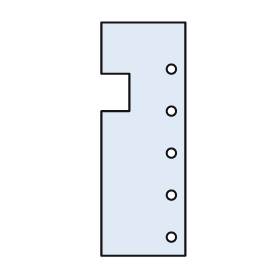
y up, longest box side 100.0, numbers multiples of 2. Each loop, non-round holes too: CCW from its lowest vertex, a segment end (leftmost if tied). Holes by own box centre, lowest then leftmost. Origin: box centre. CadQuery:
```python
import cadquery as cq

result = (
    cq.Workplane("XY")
    .moveTo(-18.0, -50.0)
    .lineTo(18.0, -50.0)
    .lineTo(18.0, 50.0)
    .lineTo(-18.0, 50.0)
    .lineTo(-18.0, 28.0)
    .lineTo(-6.0, 28.0)
    .lineTo(-6.0, 12.0)
    .lineTo(-18.0, 12.0)
    .close()
    .moveTo(12.0, -42.0)
    .circle(2.0)
    .moveTo(12.0, -24.0)
    .circle(2.0)
    .moveTo(12.0, -6.0)
    .circle(2.0)
    .moveTo(12.0, 12.0)
    .circle(2.0)
    .moveTo(12.0, 30.0)
    .circle(2.0)
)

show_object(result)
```